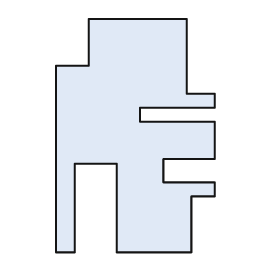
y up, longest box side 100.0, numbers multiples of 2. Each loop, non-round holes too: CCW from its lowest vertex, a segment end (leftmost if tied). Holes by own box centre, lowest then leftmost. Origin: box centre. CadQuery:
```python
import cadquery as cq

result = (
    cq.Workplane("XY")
    .moveTo(-34.0, -50.0)
    .lineTo(-26.0, -50.0)
    .lineTo(-26.0, -12.0)
    .lineTo(-8.0, -12.0)
    .lineTo(-8.0, -50.0)
    .lineTo(24.0, -50.0)
    .lineTo(24.0, -26.0)
    .lineTo(34.0, -26.0)
    .lineTo(34.0, -20.0)
    .lineTo(12.0, -20.0)
    .lineTo(12.0, -10.0)
    .lineTo(34.0, -10.0)
    .lineTo(34.0, 6.0)
    .lineTo(2.0, 6.0)
    .lineTo(2.0, 12.0)
    .lineTo(34.0, 12.0)
    .lineTo(34.0, 18.0)
    .lineTo(22.0, 18.0)
    .lineTo(22.0, 50.0)
    .lineTo(-20.0, 50.0)
    .lineTo(-20.0, 30.0)
    .lineTo(-34.0, 30.0)
    .close()
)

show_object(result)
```